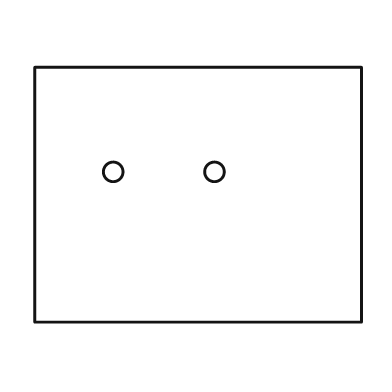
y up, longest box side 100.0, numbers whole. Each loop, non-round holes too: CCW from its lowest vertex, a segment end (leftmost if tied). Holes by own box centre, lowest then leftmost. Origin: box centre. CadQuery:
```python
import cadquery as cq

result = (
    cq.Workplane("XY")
    .moveTo(-50.0, -39.0)
    .lineTo(50.0, -39.0)
    .lineTo(50.0, 39.0)
    .lineTo(-50.0, 39.0)
    .close()
    .moveTo(-26.0, 7.0)
    .circle(3.0)
    .moveTo(5.0, 7.0)
    .circle(3.0)
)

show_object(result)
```